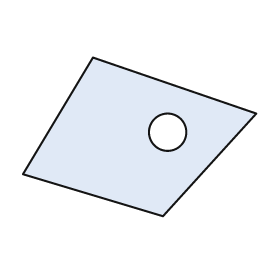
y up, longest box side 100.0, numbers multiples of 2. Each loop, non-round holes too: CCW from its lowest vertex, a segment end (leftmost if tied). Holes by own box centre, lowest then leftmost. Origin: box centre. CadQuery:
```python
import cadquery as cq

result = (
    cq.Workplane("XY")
    .moveTo(10.0, -34.0)
    .lineTo(50.0, 10.0)
    .lineTo(-20.0, 34.0)
    .lineTo(-50.0, -16.0)
    .close()
    .moveTo(12.0, 2.0)
    .circle(8.0)
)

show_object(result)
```